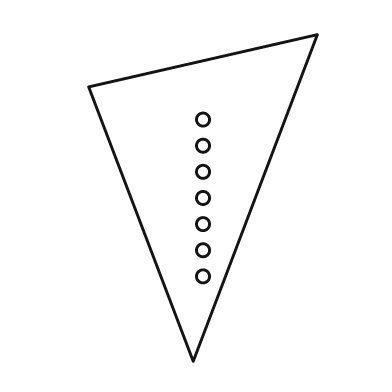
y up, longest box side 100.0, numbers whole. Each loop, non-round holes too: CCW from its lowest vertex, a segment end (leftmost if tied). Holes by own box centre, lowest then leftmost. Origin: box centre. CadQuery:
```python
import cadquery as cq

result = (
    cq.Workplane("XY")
    .moveTo(-3.0, -50.0)
    .lineTo(35.0, 50.0)
    .lineTo(-35.0, 34.0)
    .close()
    .moveTo(0.0, -24.0)
    .circle(2.0)
    .moveTo(0.0, -16.0)
    .circle(2.0)
    .moveTo(0.0, -8.0)
    .circle(2.0)
    .moveTo(0.0, 0.0)
    .circle(2.0)
    .moveTo(0.0, 8.0)
    .circle(2.0)
    .moveTo(0.0, 16.0)
    .circle(2.0)
    .moveTo(0.0, 24.0)
    .circle(2.0)
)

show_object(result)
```